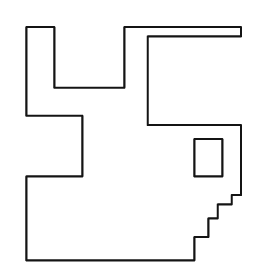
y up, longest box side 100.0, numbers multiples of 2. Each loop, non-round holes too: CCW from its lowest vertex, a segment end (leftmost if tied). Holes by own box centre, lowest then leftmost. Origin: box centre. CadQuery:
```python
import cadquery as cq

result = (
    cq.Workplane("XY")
    .moveTo(-46.0, -50.0)
    .lineTo(26.0, -50.0)
    .lineTo(26.0, -40.0)
    .lineTo(32.0, -40.0)
    .lineTo(32.0, -32.0)
    .lineTo(36.0, -32.0)
    .lineTo(36.0, -26.0)
    .lineTo(42.0, -26.0)
    .lineTo(42.0, -22.0)
    .lineTo(46.0, -22.0)
    .lineTo(46.0, 8.0)
    .lineTo(6.0, 8.0)
    .lineTo(6.0, 46.0)
    .lineTo(46.0, 46.0)
    .lineTo(46.0, 50.0)
    .lineTo(-4.0, 50.0)
    .lineTo(-4.0, 24.0)
    .lineTo(-34.0, 24.0)
    .lineTo(-34.0, 50.0)
    .lineTo(-46.0, 50.0)
    .lineTo(-46.0, 12.0)
    .lineTo(-22.0, 12.0)
    .lineTo(-22.0, -14.0)
    .lineTo(-46.0, -14.0)
    .close()
    .moveTo(26.0, -14.0)
    .lineTo(38.0, -14.0)
    .lineTo(38.0, 2.0)
    .lineTo(26.0, 2.0)
    .close()
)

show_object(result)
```